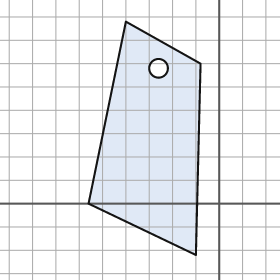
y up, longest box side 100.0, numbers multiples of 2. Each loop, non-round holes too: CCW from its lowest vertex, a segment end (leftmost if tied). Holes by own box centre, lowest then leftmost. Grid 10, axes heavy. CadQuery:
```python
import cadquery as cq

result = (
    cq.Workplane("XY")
    .moveTo(-10.0, -22.0)
    .lineTo(-8.0, 60.0)
    .lineTo(-40.0, 78.0)
    .lineTo(-56.0, 0.0)
    .close()
    .moveTo(-26.0, 58.0)
    .circle(4.0)
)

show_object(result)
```